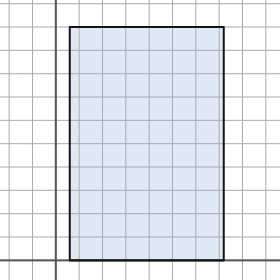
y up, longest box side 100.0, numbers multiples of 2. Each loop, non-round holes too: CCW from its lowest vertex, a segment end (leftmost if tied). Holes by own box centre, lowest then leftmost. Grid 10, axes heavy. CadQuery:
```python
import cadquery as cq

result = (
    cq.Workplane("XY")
    .moveTo(6.0, 0.0)
    .lineTo(72.0, 0.0)
    .lineTo(72.0, 100.0)
    .lineTo(6.0, 100.0)
    .close()
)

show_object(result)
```